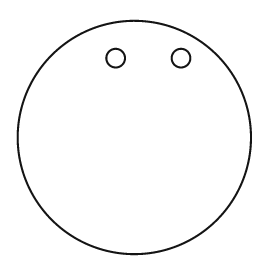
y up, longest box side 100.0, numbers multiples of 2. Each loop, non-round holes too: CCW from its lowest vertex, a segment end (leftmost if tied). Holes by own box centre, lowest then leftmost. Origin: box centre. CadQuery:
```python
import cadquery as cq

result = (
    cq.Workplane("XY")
    .moveTo(0.0, 0.0)
    .circle(50.0)
    .moveTo(-8.0, 34.0)
    .circle(4.0)
    .moveTo(20.0, 34.0)
    .circle(4.0)
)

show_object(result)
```